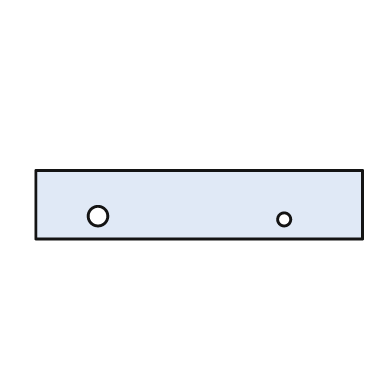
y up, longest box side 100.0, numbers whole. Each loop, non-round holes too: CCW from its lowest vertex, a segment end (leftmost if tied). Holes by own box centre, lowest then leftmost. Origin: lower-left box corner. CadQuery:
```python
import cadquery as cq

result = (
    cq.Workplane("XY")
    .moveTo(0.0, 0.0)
    .lineTo(100.0, 0.0)
    .lineTo(100.0, 21.0)
    .lineTo(0.0, 21.0)
    .close()
    .moveTo(76.0, 6.0)
    .circle(2.0)
    .moveTo(19.0, 7.0)
    .circle(3.0)
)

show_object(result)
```